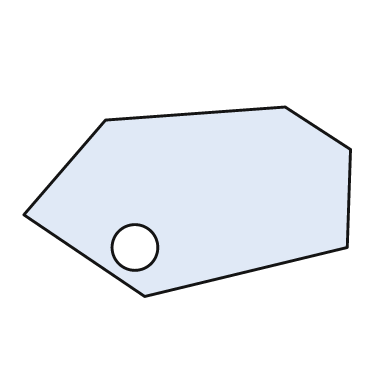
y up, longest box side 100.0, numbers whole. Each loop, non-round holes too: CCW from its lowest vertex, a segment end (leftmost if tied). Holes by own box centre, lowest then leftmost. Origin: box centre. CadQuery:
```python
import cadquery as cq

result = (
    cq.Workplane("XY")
    .moveTo(-13.0, -29.0)
    .lineTo(49.0, -14.0)
    .lineTo(50.0, 16.0)
    .lineTo(30.0, 29.0)
    .lineTo(-25.0, 25.0)
    .lineTo(-50.0, -4.0)
    .close()
    .moveTo(-16.0, -14.0)
    .circle(7.0)
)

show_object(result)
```